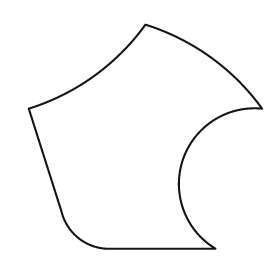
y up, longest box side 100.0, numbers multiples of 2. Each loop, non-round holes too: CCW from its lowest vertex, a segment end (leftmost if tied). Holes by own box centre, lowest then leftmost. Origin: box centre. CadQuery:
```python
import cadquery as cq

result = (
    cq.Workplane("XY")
    .moveTo(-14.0, -48.0)
    .lineTo(30.0, -48.0)
    .threePointArc((16.0, -10.0), (50.0, 12.0))
    .threePointArc((28.0, 34.0), (0.0, 48.0))
    .threePointArc((-22.0, 26.0), (-50.0, 12.0))
    .lineTo(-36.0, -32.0)
    .threePointArc((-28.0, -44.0), (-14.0, -48.0))
    .close()
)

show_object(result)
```